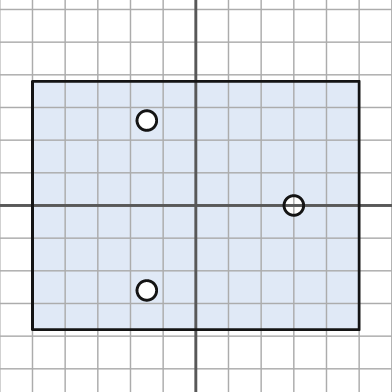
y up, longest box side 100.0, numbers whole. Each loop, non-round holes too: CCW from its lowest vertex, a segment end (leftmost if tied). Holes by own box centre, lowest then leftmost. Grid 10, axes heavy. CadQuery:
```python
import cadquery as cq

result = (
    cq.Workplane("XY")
    .moveTo(-50.0, -38.0)
    .lineTo(50.0, -38.0)
    .lineTo(50.0, 38.0)
    .lineTo(-50.0, 38.0)
    .close()
    .moveTo(-15.0, -26.0)
    .circle(3.0)
    .moveTo(30.0, 0.0)
    .circle(3.0)
    .moveTo(-15.0, 26.0)
    .circle(3.0)
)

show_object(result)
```